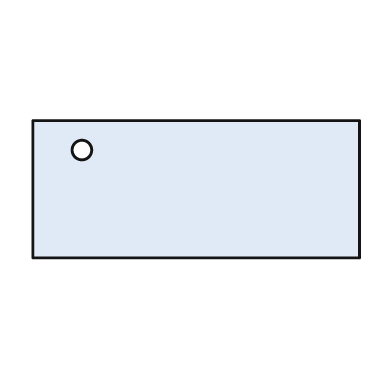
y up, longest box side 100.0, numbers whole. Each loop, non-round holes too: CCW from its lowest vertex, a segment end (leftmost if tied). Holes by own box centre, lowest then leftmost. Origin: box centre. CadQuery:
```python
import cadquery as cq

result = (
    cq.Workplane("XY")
    .moveTo(-50.0, -21.0)
    .lineTo(50.0, -21.0)
    .lineTo(50.0, 21.0)
    .lineTo(-50.0, 21.0)
    .close()
    .moveTo(-35.0, 12.0)
    .circle(3.0)
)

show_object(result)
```